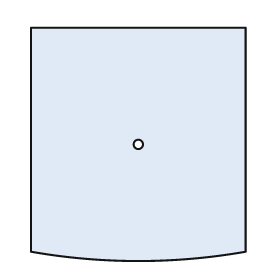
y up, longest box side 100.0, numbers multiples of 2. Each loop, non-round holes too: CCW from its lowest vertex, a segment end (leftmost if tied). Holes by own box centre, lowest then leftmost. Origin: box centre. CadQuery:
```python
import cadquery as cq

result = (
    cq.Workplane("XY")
    .moveTo(-46.0, -46.0)
    .threePointArc((0.0, -50.0), (46.0, -46.0))
    .lineTo(46.0, 50.0)
    .lineTo(-46.0, 50.0)
    .close()
    .moveTo(0.0, 0.0)
    .circle(2.0)
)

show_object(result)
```